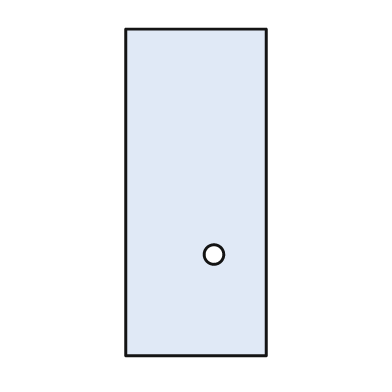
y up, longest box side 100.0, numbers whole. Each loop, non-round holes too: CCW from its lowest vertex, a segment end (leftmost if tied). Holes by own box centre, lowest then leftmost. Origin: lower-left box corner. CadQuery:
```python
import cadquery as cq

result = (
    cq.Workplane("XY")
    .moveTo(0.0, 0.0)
    .lineTo(43.0, 0.0)
    .lineTo(43.0, 100.0)
    .lineTo(0.0, 100.0)
    .close()
    .moveTo(27.0, 31.0)
    .circle(3.0)
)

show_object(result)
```